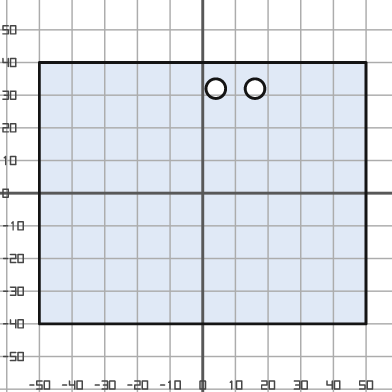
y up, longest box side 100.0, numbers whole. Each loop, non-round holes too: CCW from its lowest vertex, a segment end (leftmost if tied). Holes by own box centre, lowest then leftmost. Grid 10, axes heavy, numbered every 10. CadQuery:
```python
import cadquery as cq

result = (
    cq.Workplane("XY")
    .moveTo(-50.0, -40.0)
    .lineTo(50.0, -40.0)
    .lineTo(50.0, 40.0)
    .lineTo(-50.0, 40.0)
    .close()
    .moveTo(4.0, 32.0)
    .circle(3.0)
    .moveTo(16.0, 32.0)
    .circle(3.0)
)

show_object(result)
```